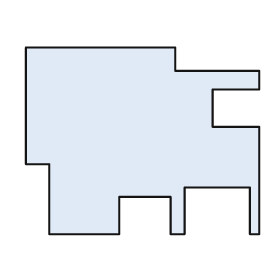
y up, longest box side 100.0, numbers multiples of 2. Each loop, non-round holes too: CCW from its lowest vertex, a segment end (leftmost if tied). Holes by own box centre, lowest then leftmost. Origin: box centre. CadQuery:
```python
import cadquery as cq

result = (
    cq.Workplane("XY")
    .moveTo(-40.0, -40.0)
    .lineTo(-10.0, -40.0)
    .lineTo(-10.0, -24.0)
    .lineTo(12.0, -24.0)
    .lineTo(12.0, -40.0)
    .lineTo(18.0, -40.0)
    .lineTo(18.0, -20.0)
    .lineTo(46.0, -20.0)
    .lineTo(46.0, -40.0)
    .lineTo(50.0, -40.0)
    .lineTo(50.0, 6.0)
    .lineTo(30.0, 6.0)
    .lineTo(30.0, 22.0)
    .lineTo(50.0, 22.0)
    .lineTo(50.0, 30.0)
    .lineTo(14.0, 30.0)
    .lineTo(14.0, 40.0)
    .lineTo(-50.0, 40.0)
    .lineTo(-50.0, -10.0)
    .lineTo(-40.0, -10.0)
    .close()
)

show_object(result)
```